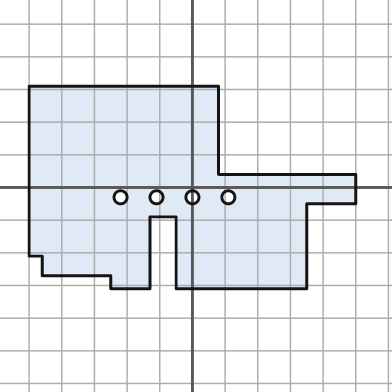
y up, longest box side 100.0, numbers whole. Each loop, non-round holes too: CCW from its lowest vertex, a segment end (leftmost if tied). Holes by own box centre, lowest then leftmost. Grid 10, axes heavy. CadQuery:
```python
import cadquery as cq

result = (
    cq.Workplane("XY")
    .moveTo(-25.0, -31.0)
    .lineTo(-13.0, -31.0)
    .lineTo(-13.0, -9.0)
    .lineTo(-5.0, -9.0)
    .lineTo(-5.0, -31.0)
    .lineTo(35.0, -31.0)
    .lineTo(35.0, -5.0)
    .lineTo(50.0, -5.0)
    .lineTo(50.0, 4.0)
    .lineTo(8.0, 4.0)
    .lineTo(8.0, 31.0)
    .lineTo(-50.0, 31.0)
    .lineTo(-50.0, -21.0)
    .lineTo(-46.0, -21.0)
    .lineTo(-46.0, -27.0)
    .lineTo(-25.0, -27.0)
    .close()
    .moveTo(-22.0, -3.0)
    .circle(2.0)
    .moveTo(-11.0, -3.0)
    .circle(2.0)
    .moveTo(0.0, -3.0)
    .circle(2.0)
    .moveTo(11.0, -3.0)
    .circle(2.0)
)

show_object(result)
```